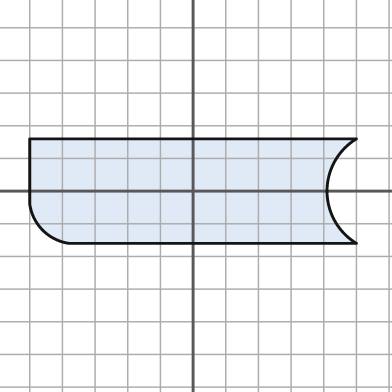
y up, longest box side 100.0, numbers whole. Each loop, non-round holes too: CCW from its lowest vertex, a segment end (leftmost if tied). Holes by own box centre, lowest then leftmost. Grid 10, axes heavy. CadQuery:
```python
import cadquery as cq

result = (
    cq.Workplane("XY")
    .moveTo(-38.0, -16.0)
    .lineTo(50.0, -16.0)
    .threePointArc((41.0, 0.0), (50.0, 16.0))
    .lineTo(-50.0, 16.0)
    .lineTo(-50.0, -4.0)
    .threePointArc((-46.0, -12.0), (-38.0, -16.0))
    .close()
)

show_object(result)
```